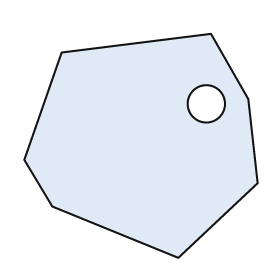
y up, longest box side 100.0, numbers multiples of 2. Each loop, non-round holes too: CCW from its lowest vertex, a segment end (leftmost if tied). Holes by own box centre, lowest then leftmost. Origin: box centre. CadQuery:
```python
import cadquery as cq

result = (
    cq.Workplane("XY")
    .moveTo(16.0, -48.0)
    .lineTo(50.0, -16.0)
    .lineTo(46.0, 20.0)
    .lineTo(30.0, 48.0)
    .lineTo(-34.0, 40.0)
    .lineTo(-50.0, -6.0)
    .lineTo(-38.0, -26.0)
    .close()
    .moveTo(28.0, 18.0)
    .circle(8.0)
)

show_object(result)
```